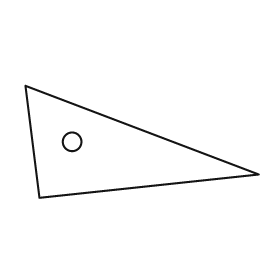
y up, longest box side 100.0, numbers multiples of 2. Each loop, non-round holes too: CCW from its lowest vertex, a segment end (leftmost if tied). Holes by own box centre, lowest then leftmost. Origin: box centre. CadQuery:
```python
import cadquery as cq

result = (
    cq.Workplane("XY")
    .moveTo(-44.0, -24.0)
    .lineTo(50.0, -14.0)
    .lineTo(-50.0, 24.0)
    .close()
    .moveTo(-30.0, 0.0)
    .circle(4.0)
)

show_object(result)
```